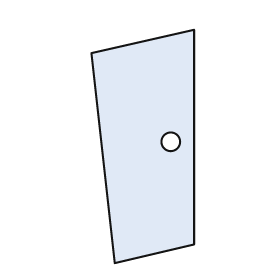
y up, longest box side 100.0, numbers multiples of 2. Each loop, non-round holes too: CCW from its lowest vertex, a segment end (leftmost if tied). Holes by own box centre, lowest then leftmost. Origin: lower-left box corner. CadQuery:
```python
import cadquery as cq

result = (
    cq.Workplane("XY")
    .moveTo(10.0, 0.0)
    .lineTo(44.0, 8.0)
    .lineTo(44.0, 100.0)
    .lineTo(0.0, 90.0)
    .close()
    .moveTo(34.0, 52.0)
    .circle(4.0)
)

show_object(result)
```